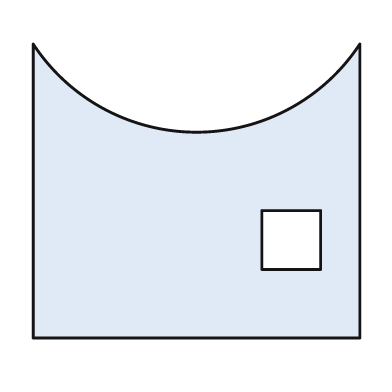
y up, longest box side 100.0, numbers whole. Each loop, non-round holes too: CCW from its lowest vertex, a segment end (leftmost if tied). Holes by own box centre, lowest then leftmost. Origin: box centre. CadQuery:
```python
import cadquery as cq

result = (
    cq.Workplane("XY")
    .moveTo(-50.0, -45.0)
    .lineTo(50.0, -45.0)
    .lineTo(50.0, 45.0)
    .threePointArc((0.0, 18.0), (-50.0, 45.0))
    .close()
    .moveTo(20.0, -24.0)
    .lineTo(38.0, -24.0)
    .lineTo(38.0, -6.0)
    .lineTo(20.0, -6.0)
    .close()
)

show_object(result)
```